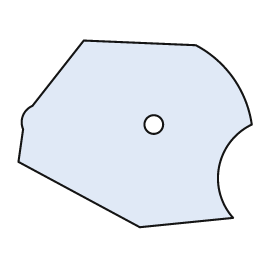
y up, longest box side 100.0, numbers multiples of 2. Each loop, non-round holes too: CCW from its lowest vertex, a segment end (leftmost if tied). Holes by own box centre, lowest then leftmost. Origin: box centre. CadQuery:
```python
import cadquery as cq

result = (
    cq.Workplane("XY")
    .moveTo(2.0, -40.0)
    .lineTo(42.0, -36.0)
    .threePointArc((36.0, -14.0), (50.0, 4.0))
    .threePointArc((42.0, 24.0), (26.0, 38.0))
    .lineTo(-22.0, 40.0)
    .lineTo(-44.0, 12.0)
    .threePointArc((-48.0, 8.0), (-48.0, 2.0))
    .lineTo(-50.0, -12.0)
    .close()
    .moveTo(8.0, 4.0)
    .circle(4.0)
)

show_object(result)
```